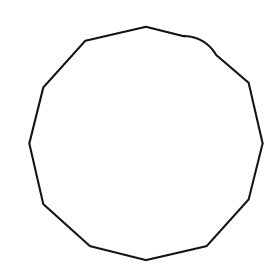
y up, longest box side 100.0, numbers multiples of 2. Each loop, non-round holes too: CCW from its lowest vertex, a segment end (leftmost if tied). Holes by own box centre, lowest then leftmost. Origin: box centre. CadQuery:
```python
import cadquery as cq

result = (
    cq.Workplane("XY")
    .moveTo(0.0, -50.0)
    .lineTo(26.0, -44.0)
    .lineTo(44.0, -24.0)
    .lineTo(50.0, 0.0)
    .lineTo(44.0, 26.0)
    .lineTo(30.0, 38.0)
    .threePointArc((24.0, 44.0), (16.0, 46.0))
    .lineTo(0.0, 50.0)
    .lineTo(-26.0, 44.0)
    .lineTo(-44.0, 24.0)
    .lineTo(-50.0, 0.0)
    .lineTo(-44.0, -26.0)
    .lineTo(-24.0, -44.0)
    .close()
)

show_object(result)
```